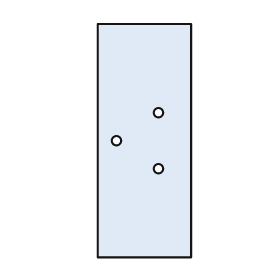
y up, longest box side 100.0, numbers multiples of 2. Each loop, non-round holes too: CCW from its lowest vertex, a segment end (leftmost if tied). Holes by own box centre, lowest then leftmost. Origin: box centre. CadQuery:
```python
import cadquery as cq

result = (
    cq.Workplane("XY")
    .moveTo(-20.0, -50.0)
    .lineTo(20.0, -50.0)
    .lineTo(20.0, 50.0)
    .lineTo(-20.0, 50.0)
    .close()
    .moveTo(6.0, -12.0)
    .circle(2.0)
    .moveTo(-12.0, 0.0)
    .circle(2.0)
    .moveTo(6.0, 12.0)
    .circle(2.0)
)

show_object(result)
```